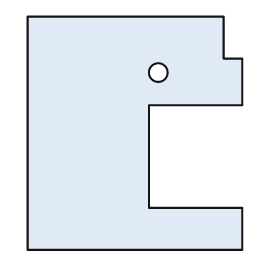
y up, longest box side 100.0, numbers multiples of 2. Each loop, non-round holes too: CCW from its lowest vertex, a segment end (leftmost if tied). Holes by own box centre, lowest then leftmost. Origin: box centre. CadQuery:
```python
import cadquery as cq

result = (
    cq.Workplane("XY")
    .moveTo(-46.0, -50.0)
    .lineTo(46.0, -50.0)
    .lineTo(46.0, -32.0)
    .lineTo(6.0, -32.0)
    .lineTo(6.0, 12.0)
    .lineTo(46.0, 12.0)
    .lineTo(46.0, 32.0)
    .lineTo(38.0, 32.0)
    .lineTo(38.0, 50.0)
    .lineTo(-46.0, 50.0)
    .close()
    .moveTo(10.0, 26.0)
    .circle(4.0)
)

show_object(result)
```